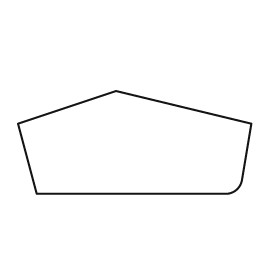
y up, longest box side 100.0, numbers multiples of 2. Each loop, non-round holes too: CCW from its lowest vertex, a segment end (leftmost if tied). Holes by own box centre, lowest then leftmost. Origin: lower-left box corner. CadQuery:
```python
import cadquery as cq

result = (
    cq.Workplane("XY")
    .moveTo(8.0, 0.0)
    .lineTo(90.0, 0.0)
    .threePointArc((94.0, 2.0), (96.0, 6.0))
    .lineTo(100.0, 30.0)
    .lineTo(42.0, 44.0)
    .lineTo(0.0, 30.0)
    .close()
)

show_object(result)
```